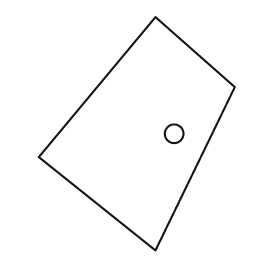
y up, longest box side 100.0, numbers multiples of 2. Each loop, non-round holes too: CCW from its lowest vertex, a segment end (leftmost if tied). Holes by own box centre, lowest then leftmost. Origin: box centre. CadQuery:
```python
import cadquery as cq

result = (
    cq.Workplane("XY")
    .moveTo(8.0, -50.0)
    .lineTo(42.0, 20.0)
    .lineTo(8.0, 50.0)
    .lineTo(-42.0, -10.0)
    .close()
    .moveTo(16.0, 0.0)
    .circle(4.0)
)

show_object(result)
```